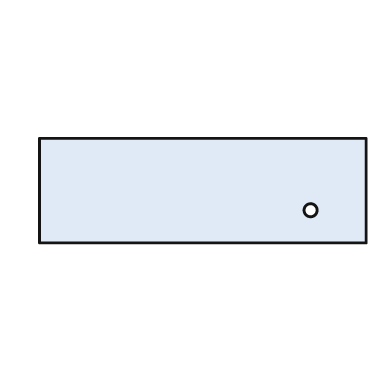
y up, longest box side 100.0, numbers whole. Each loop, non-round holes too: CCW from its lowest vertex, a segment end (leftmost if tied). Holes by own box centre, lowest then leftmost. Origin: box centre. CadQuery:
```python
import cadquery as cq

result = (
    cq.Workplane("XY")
    .moveTo(-50.0, -16.0)
    .lineTo(50.0, -16.0)
    .lineTo(50.0, 16.0)
    .lineTo(-50.0, 16.0)
    .close()
    .moveTo(33.0, -6.0)
    .circle(2.0)
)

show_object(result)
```